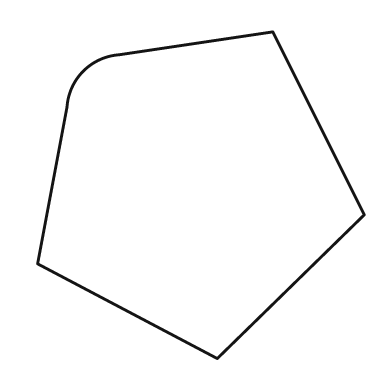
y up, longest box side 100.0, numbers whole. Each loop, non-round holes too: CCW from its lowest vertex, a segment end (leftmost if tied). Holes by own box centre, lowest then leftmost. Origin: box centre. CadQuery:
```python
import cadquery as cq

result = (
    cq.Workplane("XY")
    .moveTo(5.0, -50.0)
    .lineTo(50.0, -6.0)
    .lineTo(22.0, 50.0)
    .lineTo(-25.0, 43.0)
    .threePointArc((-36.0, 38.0), (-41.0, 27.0))
    .lineTo(-50.0, -21.0)
    .close()
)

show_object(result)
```